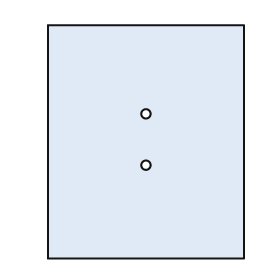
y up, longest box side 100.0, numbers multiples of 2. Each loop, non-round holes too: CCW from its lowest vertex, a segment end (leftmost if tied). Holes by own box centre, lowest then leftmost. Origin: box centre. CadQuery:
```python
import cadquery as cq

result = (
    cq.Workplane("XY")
    .moveTo(-42.0, -50.0)
    .lineTo(42.0, -50.0)
    .lineTo(42.0, 50.0)
    .lineTo(-42.0, 50.0)
    .close()
    .moveTo(0.0, -10.0)
    .circle(2.0)
    .moveTo(0.0, 12.0)
    .circle(2.0)
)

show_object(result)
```